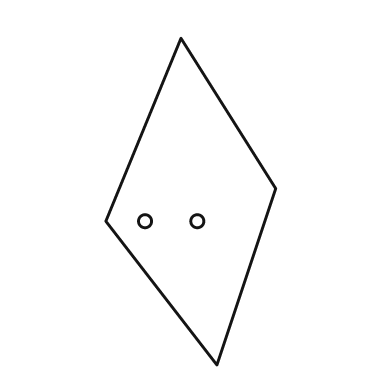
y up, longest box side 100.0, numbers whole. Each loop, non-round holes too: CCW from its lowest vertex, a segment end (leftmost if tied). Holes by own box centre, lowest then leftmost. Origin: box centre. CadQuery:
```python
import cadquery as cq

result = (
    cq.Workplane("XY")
    .moveTo(8.0, -50.0)
    .lineTo(26.0, 4.0)
    .lineTo(-3.0, 50.0)
    .lineTo(-26.0, -6.0)
    .close()
    .moveTo(-14.0, -6.0)
    .circle(2.0)
    .moveTo(2.0, -6.0)
    .circle(2.0)
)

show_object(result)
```